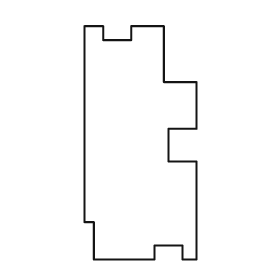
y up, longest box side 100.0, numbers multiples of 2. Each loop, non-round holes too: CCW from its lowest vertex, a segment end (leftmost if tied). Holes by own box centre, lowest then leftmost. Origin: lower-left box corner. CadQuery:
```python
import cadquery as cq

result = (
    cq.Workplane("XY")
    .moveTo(4.0, 0.0)
    .lineTo(30.0, 0.0)
    .lineTo(30.0, 6.0)
    .lineTo(42.0, 6.0)
    .lineTo(42.0, 0.0)
    .lineTo(48.0, 0.0)
    .lineTo(48.0, 42.0)
    .lineTo(36.0, 42.0)
    .lineTo(36.0, 56.0)
    .lineTo(48.0, 56.0)
    .lineTo(48.0, 76.0)
    .lineTo(34.0, 76.0)
    .lineTo(34.0, 100.0)
    .lineTo(20.0, 100.0)
    .lineTo(20.0, 94.0)
    .lineTo(8.0, 94.0)
    .lineTo(8.0, 100.0)
    .lineTo(0.0, 100.0)
    .lineTo(0.0, 16.0)
    .lineTo(4.0, 16.0)
    .close()
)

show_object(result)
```